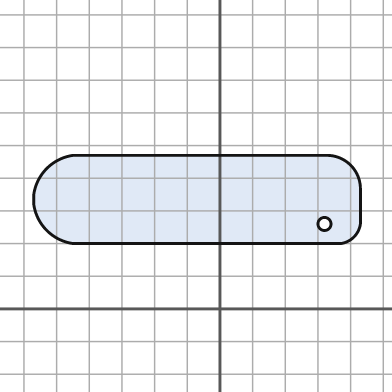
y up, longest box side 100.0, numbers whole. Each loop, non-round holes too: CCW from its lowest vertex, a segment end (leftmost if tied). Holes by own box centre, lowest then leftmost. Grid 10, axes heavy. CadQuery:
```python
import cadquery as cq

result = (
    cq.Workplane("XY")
    .moveTo(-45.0, 20.0)
    .lineTo(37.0, 20.0)
    .threePointArc((41.0, 22.0), (43.0, 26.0))
    .lineTo(43.0, 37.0)
    .threePointArc((40.0, 44.0), (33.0, 47.0))
    .lineTo(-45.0, 47.0)
    .threePointArc((-53.0, 43.0), (-57.0, 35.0))
    .lineTo(-57.0, 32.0)
    .threePointArc((-53.0, 24.0), (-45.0, 20.0))
    .close()
    .moveTo(32.0, 26.0)
    .circle(2.0)
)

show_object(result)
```